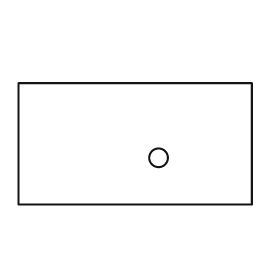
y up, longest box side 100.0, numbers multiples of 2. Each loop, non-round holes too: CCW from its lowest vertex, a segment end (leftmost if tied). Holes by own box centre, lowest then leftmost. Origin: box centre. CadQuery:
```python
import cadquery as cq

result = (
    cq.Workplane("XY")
    .moveTo(-50.0, -26.0)
    .lineTo(50.0, -26.0)
    .lineTo(50.0, 26.0)
    .lineTo(-50.0, 26.0)
    .close()
    .moveTo(10.0, -6.0)
    .circle(4.0)
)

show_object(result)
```